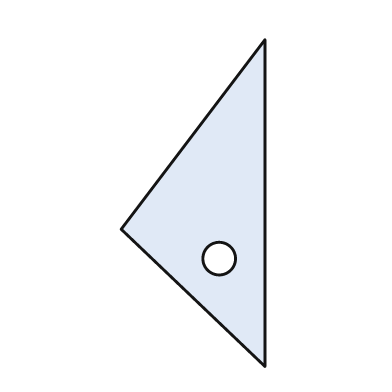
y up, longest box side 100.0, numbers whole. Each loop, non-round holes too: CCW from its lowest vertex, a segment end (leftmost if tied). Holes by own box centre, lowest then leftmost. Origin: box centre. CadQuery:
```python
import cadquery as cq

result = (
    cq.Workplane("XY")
    .moveTo(22.0, -50.0)
    .lineTo(22.0, 50.0)
    .lineTo(-22.0, -8.0)
    .close()
    .moveTo(8.0, -17.0)
    .circle(5.0)
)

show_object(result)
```